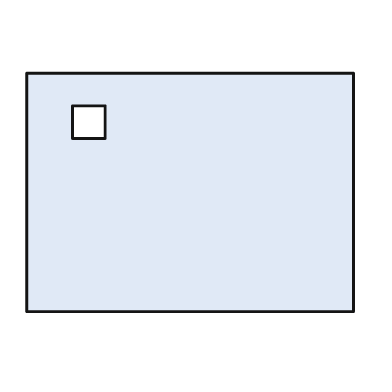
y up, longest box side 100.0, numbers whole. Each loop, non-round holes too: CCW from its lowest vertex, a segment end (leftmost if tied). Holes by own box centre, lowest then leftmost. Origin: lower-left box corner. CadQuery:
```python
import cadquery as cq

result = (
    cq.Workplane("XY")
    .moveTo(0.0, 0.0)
    .lineTo(100.0, 0.0)
    .lineTo(100.0, 73.0)
    .lineTo(0.0, 73.0)
    .close()
    .moveTo(14.0, 53.0)
    .lineTo(24.0, 53.0)
    .lineTo(24.0, 63.0)
    .lineTo(14.0, 63.0)
    .close()
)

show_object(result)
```